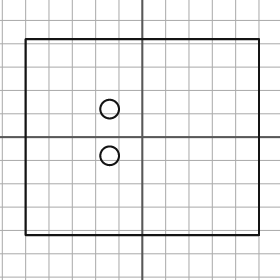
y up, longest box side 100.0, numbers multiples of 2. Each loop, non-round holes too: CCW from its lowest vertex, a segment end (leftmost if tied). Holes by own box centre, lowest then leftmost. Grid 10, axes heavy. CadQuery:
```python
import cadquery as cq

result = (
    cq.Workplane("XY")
    .moveTo(-50.0, -42.0)
    .lineTo(50.0, -42.0)
    .lineTo(50.0, 42.0)
    .lineTo(-50.0, 42.0)
    .close()
    .moveTo(-14.0, -8.0)
    .circle(4.0)
    .moveTo(-14.0, 12.0)
    .circle(4.0)
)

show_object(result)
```